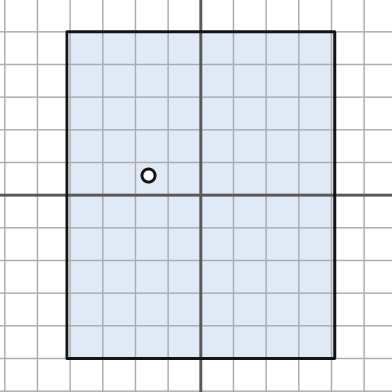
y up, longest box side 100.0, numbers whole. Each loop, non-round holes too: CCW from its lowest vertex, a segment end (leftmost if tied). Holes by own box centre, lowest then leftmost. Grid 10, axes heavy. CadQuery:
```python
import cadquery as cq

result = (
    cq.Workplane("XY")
    .moveTo(-41.0, -50.0)
    .lineTo(41.0, -50.0)
    .lineTo(41.0, 50.0)
    .lineTo(-41.0, 50.0)
    .close()
    .moveTo(-16.0, 6.0)
    .circle(2.0)
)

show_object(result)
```